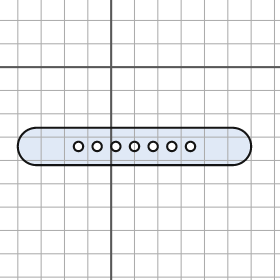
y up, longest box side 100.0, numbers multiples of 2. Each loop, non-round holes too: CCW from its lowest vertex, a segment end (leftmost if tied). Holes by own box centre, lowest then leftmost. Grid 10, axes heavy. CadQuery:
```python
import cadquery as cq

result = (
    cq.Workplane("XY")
    .moveTo(-32.0, -42.0)
    .lineTo(52.0, -42.0)
    .threePointArc((60.0, -34.0), (52.0, -26.0))
    .lineTo(-32.0, -26.0)
    .threePointArc((-40.0, -34.0), (-32.0, -42.0))
    .close()
    .moveTo(-14.0, -34.0)
    .circle(2.0)
    .moveTo(-6.0, -34.0)
    .circle(2.0)
    .moveTo(2.0, -34.0)
    .circle(2.0)
    .moveTo(10.0, -34.0)
    .circle(2.0)
    .moveTo(18.0, -34.0)
    .circle(2.0)
    .moveTo(26.0, -34.0)
    .circle(2.0)
    .moveTo(34.0, -34.0)
    .circle(2.0)
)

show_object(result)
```